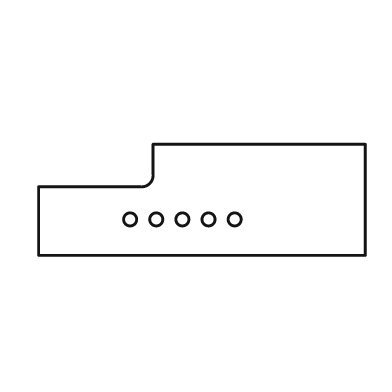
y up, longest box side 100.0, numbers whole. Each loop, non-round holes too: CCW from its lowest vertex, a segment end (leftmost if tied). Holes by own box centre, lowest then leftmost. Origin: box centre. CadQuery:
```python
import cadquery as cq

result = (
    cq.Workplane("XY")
    .moveTo(-50.0, -17.0)
    .lineTo(50.0, -17.0)
    .lineTo(50.0, 17.0)
    .lineTo(-15.0, 17.0)
    .lineTo(-15.0, 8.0)
    .threePointArc((-16.0, 5.0), (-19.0, 4.0))
    .lineTo(-50.0, 4.0)
    .close()
    .moveTo(-22.0, -6.0)
    .circle(2.0)
    .moveTo(-14.0, -6.0)
    .circle(2.0)
    .moveTo(-6.0, -6.0)
    .circle(2.0)
    .moveTo(2.0, -6.0)
    .circle(2.0)
    .moveTo(10.0, -6.0)
    .circle(2.0)
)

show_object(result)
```